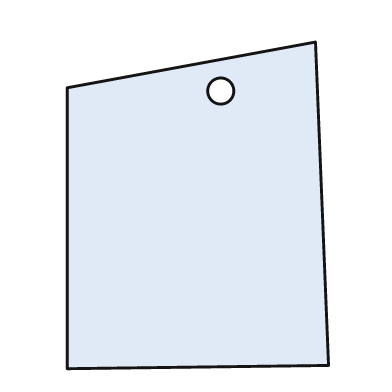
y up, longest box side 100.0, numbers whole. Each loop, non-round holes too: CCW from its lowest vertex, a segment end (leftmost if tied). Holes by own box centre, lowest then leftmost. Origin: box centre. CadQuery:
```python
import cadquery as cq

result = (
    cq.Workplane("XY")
    .moveTo(-40.0, -50.0)
    .lineTo(40.0, -49.0)
    .lineTo(36.0, 50.0)
    .lineTo(-40.0, 36.0)
    .close()
    .moveTo(7.0, 35.0)
    .circle(4.0)
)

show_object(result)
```